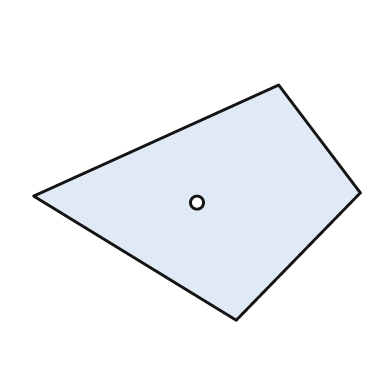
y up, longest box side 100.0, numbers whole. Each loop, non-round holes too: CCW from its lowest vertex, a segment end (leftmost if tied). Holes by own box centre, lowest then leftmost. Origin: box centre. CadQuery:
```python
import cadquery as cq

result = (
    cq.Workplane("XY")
    .moveTo(12.0, -36.0)
    .lineTo(50.0, 3.0)
    .lineTo(25.0, 36.0)
    .lineTo(-50.0, 2.0)
    .close()
    .moveTo(0.0, 0.0)
    .circle(2.0)
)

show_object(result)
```